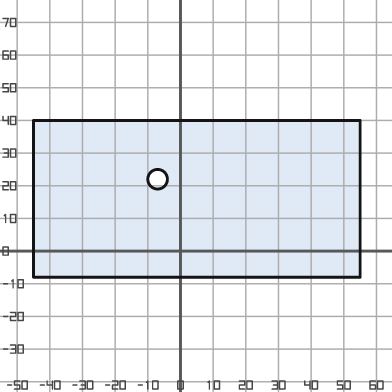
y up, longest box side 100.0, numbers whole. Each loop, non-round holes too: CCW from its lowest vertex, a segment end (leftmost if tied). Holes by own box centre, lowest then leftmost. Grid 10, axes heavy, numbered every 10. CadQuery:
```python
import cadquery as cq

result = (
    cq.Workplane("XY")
    .moveTo(-45.0, -8.0)
    .lineTo(55.0, -8.0)
    .lineTo(55.0, 40.0)
    .lineTo(-45.0, 40.0)
    .close()
    .moveTo(-7.0, 22.0)
    .circle(3.0)
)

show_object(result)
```